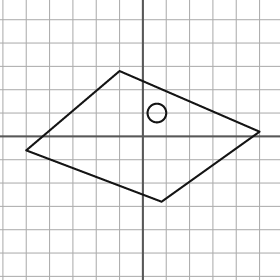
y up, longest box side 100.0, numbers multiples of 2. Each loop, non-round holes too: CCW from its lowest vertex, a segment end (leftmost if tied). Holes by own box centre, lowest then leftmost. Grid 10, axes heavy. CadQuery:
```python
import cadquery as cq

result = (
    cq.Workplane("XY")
    .moveTo(8.0, -28.0)
    .lineTo(50.0, 2.0)
    .lineTo(-10.0, 28.0)
    .lineTo(-50.0, -6.0)
    .close()
    .moveTo(6.0, 10.0)
    .circle(4.0)
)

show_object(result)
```